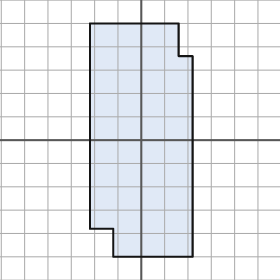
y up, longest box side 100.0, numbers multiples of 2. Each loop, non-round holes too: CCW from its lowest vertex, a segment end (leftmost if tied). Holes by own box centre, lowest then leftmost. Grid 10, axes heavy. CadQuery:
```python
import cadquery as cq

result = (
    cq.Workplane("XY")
    .moveTo(-12.0, -50.0)
    .lineTo(22.0, -50.0)
    .lineTo(22.0, 36.0)
    .lineTo(16.0, 36.0)
    .lineTo(16.0, 50.0)
    .lineTo(-22.0, 50.0)
    .lineTo(-22.0, -38.0)
    .lineTo(-12.0, -38.0)
    .close()
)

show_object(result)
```